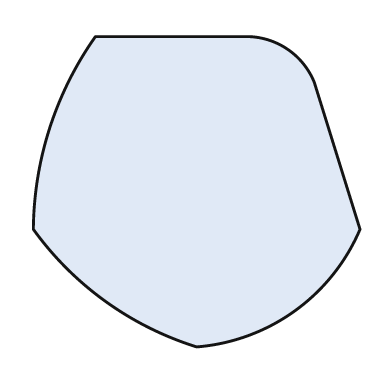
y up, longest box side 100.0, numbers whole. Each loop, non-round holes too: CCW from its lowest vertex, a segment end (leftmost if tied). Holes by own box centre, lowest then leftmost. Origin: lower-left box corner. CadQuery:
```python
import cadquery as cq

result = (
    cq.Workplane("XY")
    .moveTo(50.0, 0.0)
    .threePointArc((80.0, 11.0), (100.0, 36.0))
    .lineTo(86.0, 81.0)
    .threePointArc((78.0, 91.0), (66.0, 95.0))
    .lineTo(19.0, 95.0)
    .threePointArc((5.0, 67.0), (0.0, 36.0))
    .threePointArc((22.0, 14.0), (50.0, 0.0))
    .close()
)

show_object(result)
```